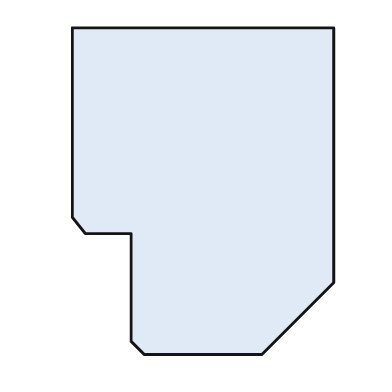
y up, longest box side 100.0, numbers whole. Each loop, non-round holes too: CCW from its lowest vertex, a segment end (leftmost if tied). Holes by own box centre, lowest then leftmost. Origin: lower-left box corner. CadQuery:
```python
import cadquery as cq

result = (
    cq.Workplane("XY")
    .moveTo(22.0, 0.0)
    .lineTo(58.0, 0.0)
    .lineTo(80.0, 22.0)
    .lineTo(80.0, 100.0)
    .lineTo(0.0, 100.0)
    .lineTo(0.0, 42.0)
    .lineTo(4.0, 37.0)
    .lineTo(18.0, 37.0)
    .lineTo(18.0, 4.0)
    .close()
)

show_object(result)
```